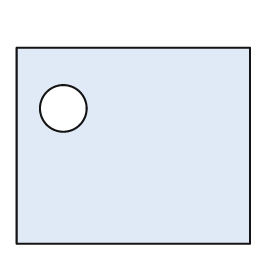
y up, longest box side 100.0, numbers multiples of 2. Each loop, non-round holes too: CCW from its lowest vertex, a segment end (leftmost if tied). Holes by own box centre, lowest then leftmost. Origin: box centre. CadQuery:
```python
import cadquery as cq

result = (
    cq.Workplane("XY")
    .moveTo(-50.0, -42.0)
    .lineTo(50.0, -42.0)
    .lineTo(50.0, 42.0)
    .lineTo(-50.0, 42.0)
    .close()
    .moveTo(-30.0, 16.0)
    .circle(10.0)
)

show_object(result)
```